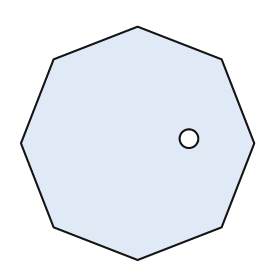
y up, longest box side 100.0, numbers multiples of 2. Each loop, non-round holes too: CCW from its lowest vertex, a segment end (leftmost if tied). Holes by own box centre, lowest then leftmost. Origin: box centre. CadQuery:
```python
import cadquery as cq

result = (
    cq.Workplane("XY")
    .moveTo(0.0, -50.0)
    .lineTo(36.0, -36.0)
    .lineTo(50.0, 0.0)
    .lineTo(36.0, 36.0)
    .lineTo(0.0, 50.0)
    .lineTo(-36.0, 36.0)
    .lineTo(-50.0, 0.0)
    .lineTo(-36.0, -36.0)
    .close()
    .moveTo(22.0, 2.0)
    .circle(4.0)
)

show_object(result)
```